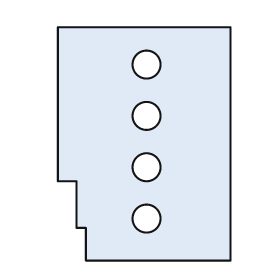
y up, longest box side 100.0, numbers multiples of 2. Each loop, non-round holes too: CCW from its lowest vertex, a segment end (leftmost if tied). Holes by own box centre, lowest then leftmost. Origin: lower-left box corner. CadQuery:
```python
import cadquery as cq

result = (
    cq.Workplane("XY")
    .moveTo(12.0, 0.0)
    .lineTo(74.0, 0.0)
    .lineTo(74.0, 100.0)
    .lineTo(0.0, 100.0)
    .lineTo(0.0, 34.0)
    .lineTo(8.0, 34.0)
    .lineTo(8.0, 14.0)
    .lineTo(12.0, 14.0)
    .close()
    .moveTo(38.0, 18.0)
    .circle(6.0)
    .moveTo(38.0, 40.0)
    .circle(6.0)
    .moveTo(38.0, 62.0)
    .circle(6.0)
    .moveTo(38.0, 84.0)
    .circle(6.0)
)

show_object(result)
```